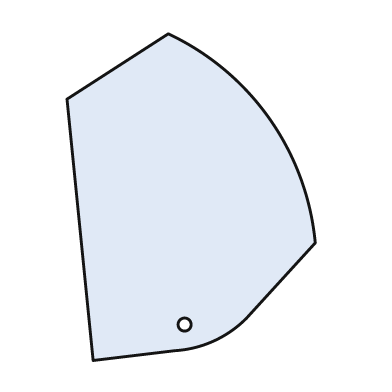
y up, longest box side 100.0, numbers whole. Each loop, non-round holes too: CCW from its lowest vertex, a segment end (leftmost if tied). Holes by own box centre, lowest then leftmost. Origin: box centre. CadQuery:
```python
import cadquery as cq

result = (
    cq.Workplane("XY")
    .moveTo(-30.0, -50.0)
    .lineTo(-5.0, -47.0)
    .threePointArc((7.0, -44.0), (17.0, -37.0))
    .lineTo(38.0, -14.0)
    .threePointArc((24.0, 24.0), (-7.0, 50.0))
    .lineTo(-38.0, 30.0)
    .close()
    .moveTo(-2.0, -39.0)
    .circle(2.0)
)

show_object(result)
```